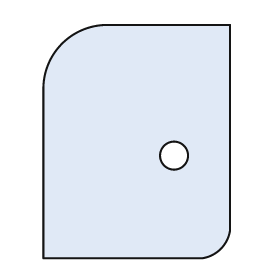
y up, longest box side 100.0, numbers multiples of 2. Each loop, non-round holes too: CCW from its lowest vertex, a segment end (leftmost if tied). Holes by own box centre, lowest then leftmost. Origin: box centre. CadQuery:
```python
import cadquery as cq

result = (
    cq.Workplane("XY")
    .moveTo(-40.0, -50.0)
    .lineTo(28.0, -50.0)
    .threePointArc((36.0, -46.0), (40.0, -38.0))
    .lineTo(40.0, 50.0)
    .lineTo(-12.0, 50.0)
    .threePointArc((-32.0, 42.0), (-40.0, 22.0))
    .close()
    .moveTo(16.0, -6.0)
    .circle(6.0)
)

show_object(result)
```